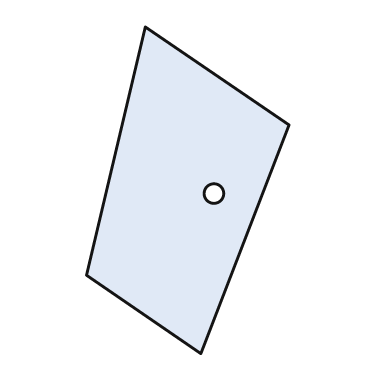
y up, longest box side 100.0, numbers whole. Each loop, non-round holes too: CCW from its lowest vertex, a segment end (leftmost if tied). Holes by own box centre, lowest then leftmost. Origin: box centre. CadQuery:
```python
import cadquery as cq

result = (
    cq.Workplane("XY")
    .moveTo(4.0, -50.0)
    .lineTo(31.0, 20.0)
    .lineTo(-13.0, 50.0)
    .lineTo(-31.0, -26.0)
    .close()
    .moveTo(8.0, -1.0)
    .circle(3.0)
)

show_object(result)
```